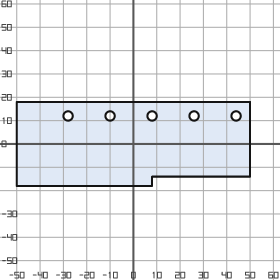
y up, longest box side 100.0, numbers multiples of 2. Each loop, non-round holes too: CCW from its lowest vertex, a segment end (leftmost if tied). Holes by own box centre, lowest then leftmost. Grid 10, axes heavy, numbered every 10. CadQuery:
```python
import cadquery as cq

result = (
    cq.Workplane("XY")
    .moveTo(-50.0, -18.0)
    .lineTo(8.0, -18.0)
    .lineTo(8.0, -14.0)
    .lineTo(50.0, -14.0)
    .lineTo(50.0, 18.0)
    .lineTo(-50.0, 18.0)
    .close()
    .moveTo(-28.0, 12.0)
    .circle(2.0)
    .moveTo(-10.0, 12.0)
    .circle(2.0)
    .moveTo(8.0, 12.0)
    .circle(2.0)
    .moveTo(26.0, 12.0)
    .circle(2.0)
    .moveTo(44.0, 12.0)
    .circle(2.0)
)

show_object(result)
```